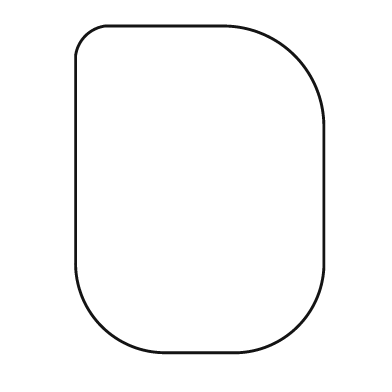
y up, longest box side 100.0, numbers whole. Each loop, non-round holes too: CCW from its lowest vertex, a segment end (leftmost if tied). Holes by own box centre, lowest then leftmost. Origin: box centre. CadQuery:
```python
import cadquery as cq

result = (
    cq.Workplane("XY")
    .moveTo(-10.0, -50.0)
    .lineTo(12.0, -50.0)
    .threePointArc((30.0, -42.0), (38.0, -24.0))
    .lineTo(38.0, 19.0)
    .threePointArc((29.0, 41.0), (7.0, 50.0))
    .lineTo(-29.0, 50.0)
    .threePointArc((-35.0, 47.0), (-38.0, 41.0))
    .lineTo(-38.0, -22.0)
    .threePointArc((-30.0, -42.0), (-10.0, -50.0))
    .close()
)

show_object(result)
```